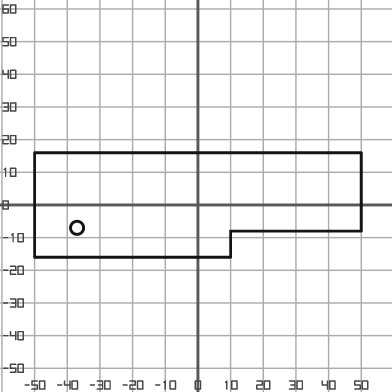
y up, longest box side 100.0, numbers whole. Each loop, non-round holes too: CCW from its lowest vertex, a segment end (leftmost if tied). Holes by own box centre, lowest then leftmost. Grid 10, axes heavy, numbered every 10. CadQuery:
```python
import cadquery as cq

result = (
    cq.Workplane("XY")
    .moveTo(-50.0, -16.0)
    .lineTo(10.0, -16.0)
    .lineTo(10.0, -8.0)
    .lineTo(50.0, -8.0)
    .lineTo(50.0, 16.0)
    .lineTo(-50.0, 16.0)
    .close()
    .moveTo(-37.0, -7.0)
    .circle(2.0)
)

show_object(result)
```